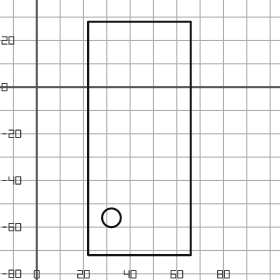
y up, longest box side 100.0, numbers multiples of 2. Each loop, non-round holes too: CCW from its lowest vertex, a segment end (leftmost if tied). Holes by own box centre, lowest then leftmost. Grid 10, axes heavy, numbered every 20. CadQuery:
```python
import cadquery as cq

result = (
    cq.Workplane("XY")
    .moveTo(22.0, -72.0)
    .lineTo(66.0, -72.0)
    .lineTo(66.0, 28.0)
    .lineTo(22.0, 28.0)
    .close()
    .moveTo(32.0, -56.0)
    .circle(4.0)
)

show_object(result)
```